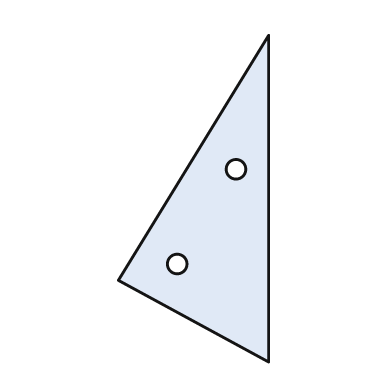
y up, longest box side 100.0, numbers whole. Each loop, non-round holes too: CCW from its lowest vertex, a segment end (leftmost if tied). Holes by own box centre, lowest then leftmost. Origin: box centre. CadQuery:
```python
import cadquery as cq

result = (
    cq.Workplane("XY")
    .moveTo(23.0, -50.0)
    .lineTo(23.0, 50.0)
    .lineTo(-23.0, -25.0)
    .close()
    .moveTo(-5.0, -20.0)
    .circle(3.0)
    .moveTo(13.0, 9.0)
    .circle(3.0)
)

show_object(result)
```